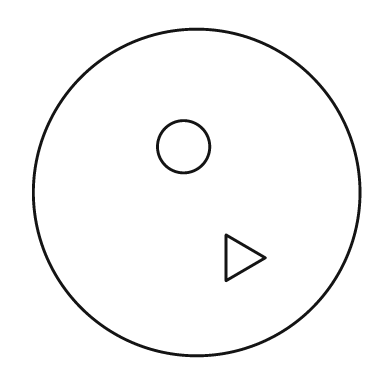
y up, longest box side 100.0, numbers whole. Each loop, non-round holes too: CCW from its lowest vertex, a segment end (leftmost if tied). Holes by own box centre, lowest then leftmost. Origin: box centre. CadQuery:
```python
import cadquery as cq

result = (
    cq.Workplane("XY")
    .moveTo(0.0, 0.0)
    .circle(50.0)
    .moveTo(9.0, -27.0)
    .lineTo(21.0, -20.0)
    .lineTo(9.0, -13.0)
    .close()
    .moveTo(-4.0, 14.0)
    .circle(8.0)
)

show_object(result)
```